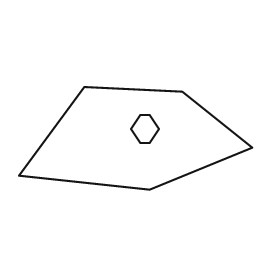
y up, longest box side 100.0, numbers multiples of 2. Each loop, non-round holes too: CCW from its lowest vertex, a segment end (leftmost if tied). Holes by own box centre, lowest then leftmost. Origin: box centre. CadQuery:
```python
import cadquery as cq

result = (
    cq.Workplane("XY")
    .moveTo(6.0, -22.0)
    .lineTo(50.0, -4.0)
    .lineTo(20.0, 20.0)
    .lineTo(-22.0, 22.0)
    .lineTo(-50.0, -16.0)
    .close()
    .moveTo(2.0, -2.0)
    .lineTo(6.0, -2.0)
    .lineTo(10.0, 4.0)
    .lineTo(6.0, 10.0)
    .lineTo(2.0, 10.0)
    .lineTo(-2.0, 4.0)
    .close()
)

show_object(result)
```